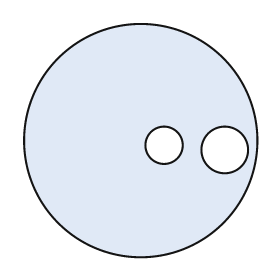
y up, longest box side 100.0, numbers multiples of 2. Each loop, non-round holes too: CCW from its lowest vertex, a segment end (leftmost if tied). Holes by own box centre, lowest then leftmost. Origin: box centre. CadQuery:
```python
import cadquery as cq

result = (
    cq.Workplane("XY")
    .moveTo(0.0, 0.0)
    .circle(50.0)
    .moveTo(36.0, -4.0)
    .circle(10.0)
    .moveTo(10.0, -2.0)
    .circle(8.0)
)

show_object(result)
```